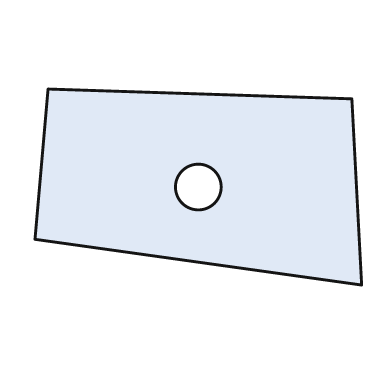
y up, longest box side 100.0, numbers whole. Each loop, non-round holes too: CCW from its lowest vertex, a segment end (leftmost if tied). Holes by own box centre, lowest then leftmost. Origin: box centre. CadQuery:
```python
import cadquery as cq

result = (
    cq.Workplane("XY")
    .moveTo(50.0, -30.0)
    .lineTo(47.0, 27.0)
    .lineTo(-46.0, 30.0)
    .lineTo(-50.0, -16.0)
    .close()
    .moveTo(0.0, 0.0)
    .circle(7.0)
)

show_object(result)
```